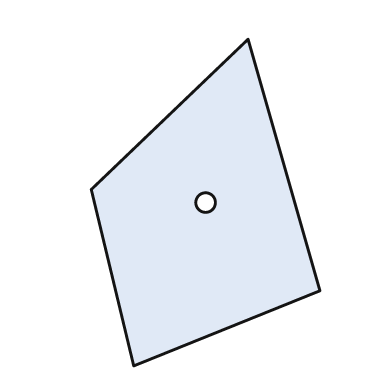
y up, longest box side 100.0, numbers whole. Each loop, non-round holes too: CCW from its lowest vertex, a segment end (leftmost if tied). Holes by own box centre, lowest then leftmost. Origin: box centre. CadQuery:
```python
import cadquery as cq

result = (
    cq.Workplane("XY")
    .moveTo(-22.0, -50.0)
    .lineTo(35.0, -27.0)
    .lineTo(13.0, 50.0)
    .lineTo(-35.0, 4.0)
    .close()
    .moveTo(0.0, 0.0)
    .circle(3.0)
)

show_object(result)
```